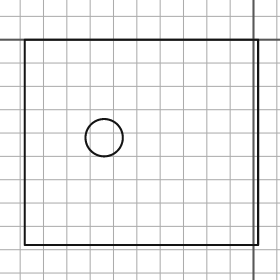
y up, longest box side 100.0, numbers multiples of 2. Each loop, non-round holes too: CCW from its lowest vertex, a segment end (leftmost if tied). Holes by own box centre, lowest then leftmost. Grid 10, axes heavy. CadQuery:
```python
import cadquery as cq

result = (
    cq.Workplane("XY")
    .moveTo(-98.0, -88.0)
    .lineTo(2.0, -88.0)
    .lineTo(2.0, 0.0)
    .lineTo(-98.0, 0.0)
    .close()
    .moveTo(-64.0, -42.0)
    .circle(8.0)
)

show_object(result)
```